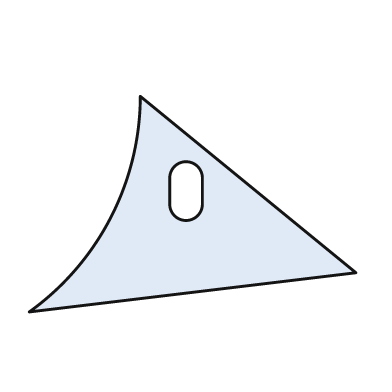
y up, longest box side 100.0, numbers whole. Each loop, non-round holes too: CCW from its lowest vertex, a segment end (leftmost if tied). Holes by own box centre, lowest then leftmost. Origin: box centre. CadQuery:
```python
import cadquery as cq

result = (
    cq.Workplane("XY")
    .moveTo(-50.0, -33.0)
    .lineTo(50.0, -21.0)
    .lineTo(-16.0, 33.0)
    .threePointArc((-25.0, -4.0), (-50.0, -33.0))
    .close()
    .moveTo(-7.0, 0.0)
    .threePointArc((-2.0, -5.0), (3.0, 0.0))
    .lineTo(3.0, 8.0)
    .threePointArc((-2.0, 13.0), (-7.0, 8.0))
    .close()
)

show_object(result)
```